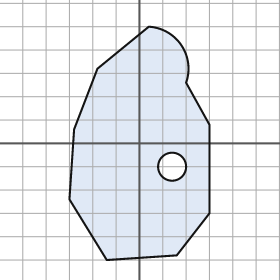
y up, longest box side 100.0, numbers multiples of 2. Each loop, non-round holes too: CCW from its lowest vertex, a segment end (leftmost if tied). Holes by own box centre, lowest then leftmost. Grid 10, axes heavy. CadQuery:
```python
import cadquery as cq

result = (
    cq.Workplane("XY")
    .moveTo(-14.0, -50.0)
    .lineTo(16.0, -48.0)
    .lineTo(30.0, -30.0)
    .lineTo(30.0, 8.0)
    .lineTo(20.0, 26.0)
    .threePointArc((18.0, 42.0), (4.0, 50.0))
    .lineTo(-18.0, 32.0)
    .lineTo(-28.0, 6.0)
    .lineTo(-30.0, -24.0)
    .close()
    .moveTo(14.0, -10.0)
    .circle(6.0)
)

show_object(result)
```